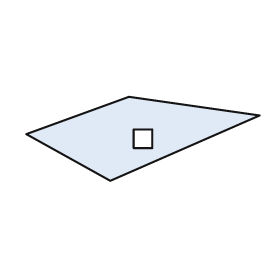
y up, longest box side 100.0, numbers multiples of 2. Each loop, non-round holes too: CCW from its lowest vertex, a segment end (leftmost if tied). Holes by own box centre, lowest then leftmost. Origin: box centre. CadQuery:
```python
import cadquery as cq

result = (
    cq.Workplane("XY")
    .moveTo(-14.0, -18.0)
    .lineTo(50.0, 10.0)
    .lineTo(-6.0, 18.0)
    .lineTo(-50.0, 2.0)
    .close()
    .moveTo(-4.0, -4.0)
    .lineTo(4.0, -4.0)
    .lineTo(4.0, 4.0)
    .lineTo(-4.0, 4.0)
    .close()
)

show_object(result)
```